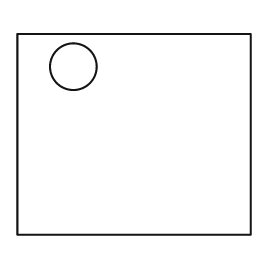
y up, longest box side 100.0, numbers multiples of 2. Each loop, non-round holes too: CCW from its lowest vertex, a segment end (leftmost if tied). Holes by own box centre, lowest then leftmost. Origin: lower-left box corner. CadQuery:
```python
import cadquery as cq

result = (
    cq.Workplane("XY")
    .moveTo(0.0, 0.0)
    .lineTo(100.0, 0.0)
    .lineTo(100.0, 86.0)
    .lineTo(0.0, 86.0)
    .close()
    .moveTo(24.0, 72.0)
    .circle(10.0)
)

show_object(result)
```